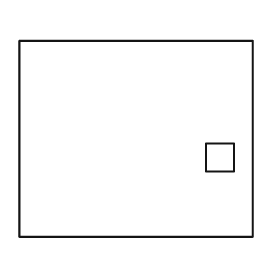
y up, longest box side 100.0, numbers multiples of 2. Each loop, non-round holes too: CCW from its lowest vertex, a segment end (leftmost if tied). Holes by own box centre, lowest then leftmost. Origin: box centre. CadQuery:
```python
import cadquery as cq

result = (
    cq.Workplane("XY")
    .moveTo(-50.0, -42.0)
    .lineTo(50.0, -42.0)
    .lineTo(50.0, 42.0)
    .lineTo(-50.0, 42.0)
    .close()
    .moveTo(30.0, -14.0)
    .lineTo(42.0, -14.0)
    .lineTo(42.0, -2.0)
    .lineTo(30.0, -2.0)
    .close()
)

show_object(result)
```